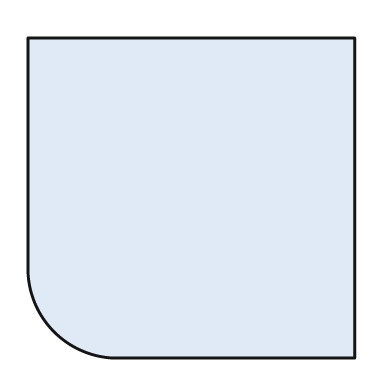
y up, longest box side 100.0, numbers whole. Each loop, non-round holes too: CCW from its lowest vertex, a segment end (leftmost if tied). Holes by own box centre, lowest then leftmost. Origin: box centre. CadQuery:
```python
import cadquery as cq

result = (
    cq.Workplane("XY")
    .moveTo(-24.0, -49.0)
    .lineTo(50.0, -49.0)
    .lineTo(50.0, 49.0)
    .lineTo(-50.0, 49.0)
    .lineTo(-50.0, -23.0)
    .threePointArc((-42.0, -41.0), (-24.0, -49.0))
    .close()
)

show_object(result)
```